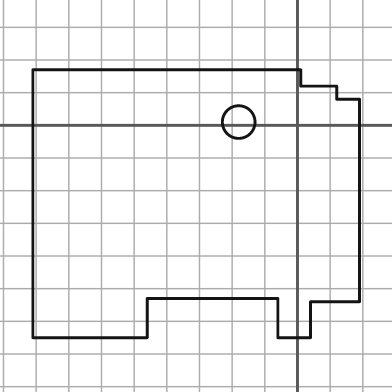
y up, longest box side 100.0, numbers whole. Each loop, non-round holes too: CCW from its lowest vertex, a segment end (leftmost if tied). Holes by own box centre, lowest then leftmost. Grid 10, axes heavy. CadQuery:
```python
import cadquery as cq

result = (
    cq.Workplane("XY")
    .moveTo(-81.0, -65.0)
    .lineTo(-46.0, -65.0)
    .lineTo(-46.0, -53.0)
    .lineTo(-6.0, -53.0)
    .lineTo(-6.0, -65.0)
    .lineTo(4.0, -65.0)
    .lineTo(4.0, -54.0)
    .lineTo(19.0, -54.0)
    .lineTo(19.0, 8.0)
    .lineTo(12.0, 8.0)
    .lineTo(12.0, 12.0)
    .lineTo(1.0, 12.0)
    .lineTo(1.0, 17.0)
    .lineTo(-81.0, 17.0)
    .close()
    .moveTo(-18.0, 1.0)
    .circle(5.0)
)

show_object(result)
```